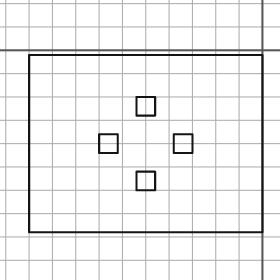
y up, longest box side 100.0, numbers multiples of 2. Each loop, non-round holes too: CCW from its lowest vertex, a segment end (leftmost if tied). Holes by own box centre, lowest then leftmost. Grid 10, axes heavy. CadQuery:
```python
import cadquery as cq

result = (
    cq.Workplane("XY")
    .moveTo(-100.0, -78.0)
    .lineTo(0.0, -78.0)
    .lineTo(0.0, -2.0)
    .lineTo(-100.0, -2.0)
    .close()
    .moveTo(-54.0, -60.0)
    .lineTo(-46.0, -60.0)
    .lineTo(-46.0, -52.0)
    .lineTo(-54.0, -52.0)
    .close()
    .moveTo(-70.0, -44.0)
    .lineTo(-62.0, -44.0)
    .lineTo(-62.0, -36.0)
    .lineTo(-70.0, -36.0)
    .close()
    .moveTo(-38.0, -44.0)
    .lineTo(-30.0, -44.0)
    .lineTo(-30.0, -36.0)
    .lineTo(-38.0, -36.0)
    .close()
    .moveTo(-54.0, -28.0)
    .lineTo(-46.0, -28.0)
    .lineTo(-46.0, -20.0)
    .lineTo(-54.0, -20.0)
    .close()
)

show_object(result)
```